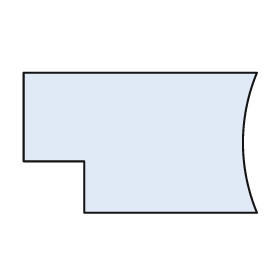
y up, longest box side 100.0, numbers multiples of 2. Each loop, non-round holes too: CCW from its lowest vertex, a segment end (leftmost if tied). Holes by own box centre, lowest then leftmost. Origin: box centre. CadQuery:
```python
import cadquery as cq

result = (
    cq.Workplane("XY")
    .moveTo(-24.0, -30.0)
    .lineTo(50.0, -30.0)
    .threePointArc((44.0, 0.0), (50.0, 30.0))
    .lineTo(-50.0, 30.0)
    .lineTo(-50.0, -8.0)
    .lineTo(-24.0, -8.0)
    .close()
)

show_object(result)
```